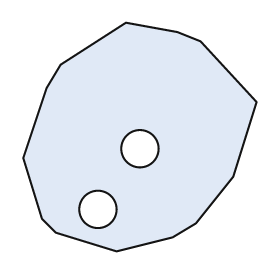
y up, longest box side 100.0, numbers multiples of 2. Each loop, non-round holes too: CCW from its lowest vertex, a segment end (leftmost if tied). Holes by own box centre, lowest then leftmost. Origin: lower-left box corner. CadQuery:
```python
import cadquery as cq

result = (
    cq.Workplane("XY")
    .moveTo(40.0, 0.0)
    .lineTo(64.0, 6.0)
    .lineTo(74.0, 12.0)
    .lineTo(90.0, 32.0)
    .lineTo(100.0, 64.0)
    .lineTo(76.0, 90.0)
    .lineTo(66.0, 94.0)
    .lineTo(44.0, 98.0)
    .lineTo(16.0, 80.0)
    .lineTo(10.0, 70.0)
    .lineTo(0.0, 40.0)
    .lineTo(8.0, 14.0)
    .lineTo(14.0, 8.0)
    .close()
    .moveTo(32.0, 18.0)
    .circle(8.0)
    .moveTo(50.0, 44.0)
    .circle(8.0)
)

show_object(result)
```